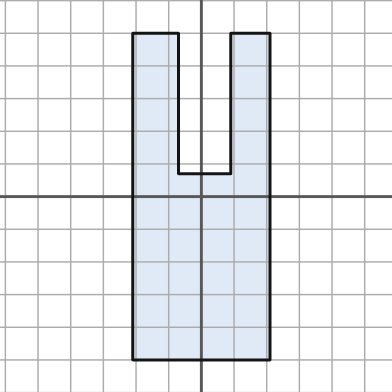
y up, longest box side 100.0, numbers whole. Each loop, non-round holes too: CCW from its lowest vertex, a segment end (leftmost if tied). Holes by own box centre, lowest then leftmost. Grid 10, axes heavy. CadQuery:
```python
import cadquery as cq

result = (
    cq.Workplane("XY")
    .moveTo(-21.0, -50.0)
    .lineTo(21.0, -50.0)
    .lineTo(21.0, 50.0)
    .lineTo(9.0, 50.0)
    .lineTo(9.0, 7.0)
    .lineTo(-7.0, 7.0)
    .lineTo(-7.0, 50.0)
    .lineTo(-21.0, 50.0)
    .close()
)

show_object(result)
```